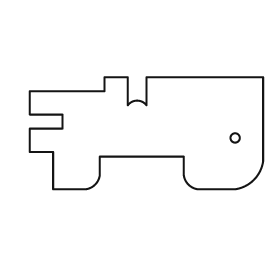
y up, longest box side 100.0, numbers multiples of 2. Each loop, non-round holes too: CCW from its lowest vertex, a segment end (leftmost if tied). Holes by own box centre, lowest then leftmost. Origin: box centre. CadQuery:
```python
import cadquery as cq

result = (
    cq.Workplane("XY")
    .moveTo(-40.0, -24.0)
    .lineTo(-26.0, -24.0)
    .threePointArc((-22.0, -22.0), (-20.0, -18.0))
    .lineTo(-20.0, -10.0)
    .lineTo(16.0, -10.0)
    .lineTo(16.0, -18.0)
    .threePointArc((18.0, -22.0), (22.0, -24.0))
    .lineTo(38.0, -24.0)
    .threePointArc((46.0, -20.0), (50.0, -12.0))
    .lineTo(50.0, 24.0)
    .lineTo(0.0, 24.0)
    .lineTo(0.0, 12.0)
    .threePointArc((-4.0, 14.0), (-8.0, 12.0))
    .lineTo(-8.0, 24.0)
    .lineTo(-18.0, 24.0)
    .lineTo(-18.0, 18.0)
    .lineTo(-50.0, 18.0)
    .lineTo(-50.0, 8.0)
    .lineTo(-36.0, 8.0)
    .lineTo(-36.0, 2.0)
    .lineTo(-50.0, 2.0)
    .lineTo(-50.0, -8.0)
    .lineTo(-40.0, -8.0)
    .close()
    .moveTo(38.0, -2.0)
    .circle(2.0)
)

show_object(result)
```